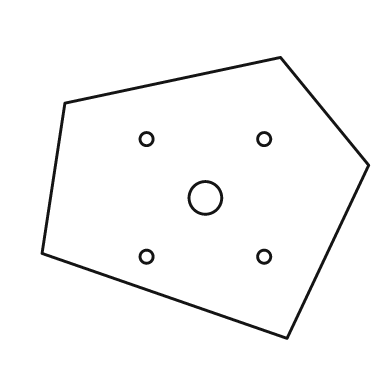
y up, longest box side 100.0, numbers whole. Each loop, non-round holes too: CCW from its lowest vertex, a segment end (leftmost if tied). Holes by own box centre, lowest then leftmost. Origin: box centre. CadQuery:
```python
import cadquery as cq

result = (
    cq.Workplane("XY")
    .moveTo(25.0, -43.0)
    .lineTo(50.0, 10.0)
    .lineTo(23.0, 43.0)
    .lineTo(-43.0, 29.0)
    .lineTo(-50.0, -17.0)
    .close()
    .moveTo(-18.0, -18.0)
    .circle(2.0)
    .moveTo(18.0, -18.0)
    .circle(2.0)
    .moveTo(0.0, 0.0)
    .circle(5.0)
    .moveTo(-18.0, 18.0)
    .circle(2.0)
    .moveTo(18.0, 18.0)
    .circle(2.0)
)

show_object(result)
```